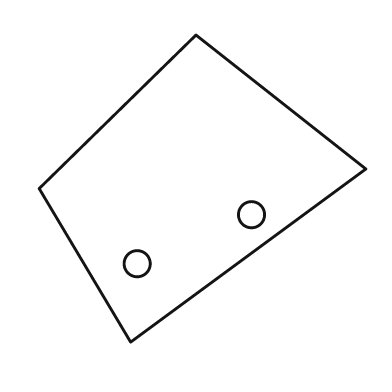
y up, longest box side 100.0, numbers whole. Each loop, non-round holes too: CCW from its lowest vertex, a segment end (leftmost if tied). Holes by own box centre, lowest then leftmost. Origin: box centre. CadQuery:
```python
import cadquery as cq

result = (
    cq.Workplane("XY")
    .moveTo(-22.0, -47.0)
    .lineTo(50.0, 6.0)
    .lineTo(-2.0, 47.0)
    .lineTo(-50.0, 0.0)
    .close()
    .moveTo(-20.0, -23.0)
    .circle(4.0)
    .moveTo(15.0, -8.0)
    .circle(4.0)
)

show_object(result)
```